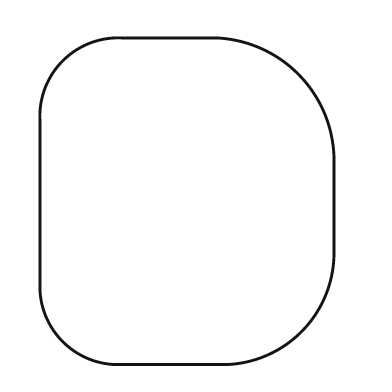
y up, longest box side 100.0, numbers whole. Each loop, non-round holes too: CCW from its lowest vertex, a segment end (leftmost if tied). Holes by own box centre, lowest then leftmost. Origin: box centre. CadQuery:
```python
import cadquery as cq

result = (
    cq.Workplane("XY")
    .moveTo(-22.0, -50.0)
    .lineTo(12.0, -50.0)
    .threePointArc((35.0, -40.0), (45.0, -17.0))
    .lineTo(45.0, 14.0)
    .threePointArc((34.0, 39.0), (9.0, 50.0))
    .lineTo(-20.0, 50.0)
    .threePointArc((-38.0, 43.0), (-45.0, 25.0))
    .lineTo(-45.0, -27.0)
    .threePointArc((-38.0, -43.0), (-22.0, -50.0))
    .close()
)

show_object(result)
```